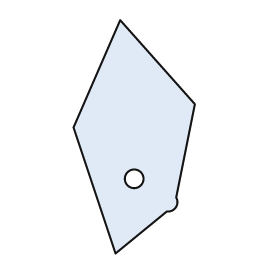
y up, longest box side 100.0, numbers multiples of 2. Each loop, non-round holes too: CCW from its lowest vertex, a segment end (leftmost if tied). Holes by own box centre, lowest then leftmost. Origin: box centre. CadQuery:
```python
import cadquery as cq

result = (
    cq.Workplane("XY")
    .moveTo(-8.0, -50.0)
    .lineTo(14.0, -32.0)
    .threePointArc((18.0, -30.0), (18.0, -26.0))
    .lineTo(26.0, 14.0)
    .lineTo(-6.0, 50.0)
    .lineTo(-26.0, 4.0)
    .close()
    .moveTo(0.0, -18.0)
    .circle(4.0)
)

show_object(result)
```